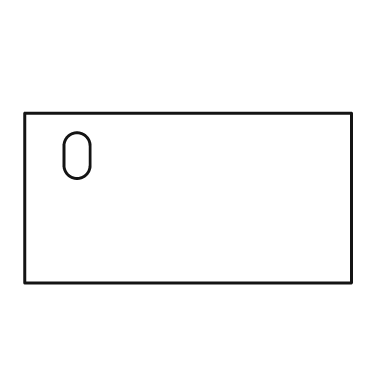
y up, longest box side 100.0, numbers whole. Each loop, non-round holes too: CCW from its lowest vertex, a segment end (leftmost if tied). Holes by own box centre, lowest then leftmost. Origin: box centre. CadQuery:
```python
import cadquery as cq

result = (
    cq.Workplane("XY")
    .moveTo(-50.0, -26.0)
    .lineTo(50.0, -26.0)
    .lineTo(50.0, 26.0)
    .lineTo(-50.0, 26.0)
    .close()
    .moveTo(-38.0, 10.0)
    .threePointArc((-34.0, 6.0), (-30.0, 10.0))
    .lineTo(-30.0, 16.0)
    .threePointArc((-34.0, 20.0), (-38.0, 16.0))
    .close()
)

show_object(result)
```